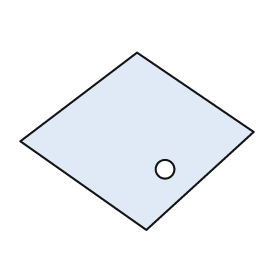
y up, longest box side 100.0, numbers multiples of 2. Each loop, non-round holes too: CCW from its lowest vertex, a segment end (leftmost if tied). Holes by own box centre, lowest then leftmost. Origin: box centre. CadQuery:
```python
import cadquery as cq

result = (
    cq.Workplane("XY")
    .moveTo(4.0, -38.0)
    .lineTo(50.0, 4.0)
    .lineTo(0.0, 38.0)
    .lineTo(-50.0, 0.0)
    .close()
    .moveTo(12.0, -12.0)
    .circle(4.0)
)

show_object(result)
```